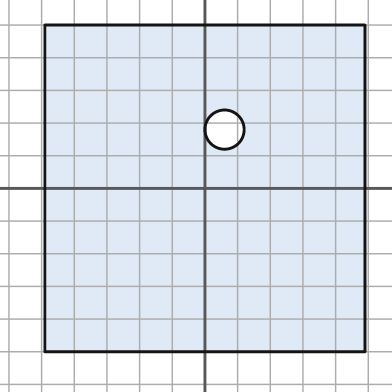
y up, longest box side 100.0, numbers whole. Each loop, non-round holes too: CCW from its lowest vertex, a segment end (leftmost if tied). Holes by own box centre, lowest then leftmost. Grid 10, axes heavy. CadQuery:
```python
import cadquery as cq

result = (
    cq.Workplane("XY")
    .moveTo(-49.0, -50.0)
    .lineTo(49.0, -50.0)
    .lineTo(49.0, 50.0)
    .lineTo(-49.0, 50.0)
    .close()
    .moveTo(6.0, 18.0)
    .circle(6.0)
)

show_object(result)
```